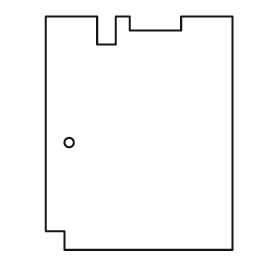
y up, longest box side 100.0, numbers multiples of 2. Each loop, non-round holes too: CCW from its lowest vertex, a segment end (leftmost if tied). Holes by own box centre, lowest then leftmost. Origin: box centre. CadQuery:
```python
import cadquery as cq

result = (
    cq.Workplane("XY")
    .moveTo(-32.0, -50.0)
    .lineTo(40.0, -50.0)
    .lineTo(40.0, 50.0)
    .lineTo(18.0, 50.0)
    .lineTo(18.0, 44.0)
    .lineTo(-4.0, 44.0)
    .lineTo(-4.0, 50.0)
    .lineTo(-10.0, 50.0)
    .lineTo(-10.0, 38.0)
    .lineTo(-18.0, 38.0)
    .lineTo(-18.0, 50.0)
    .lineTo(-40.0, 50.0)
    .lineTo(-40.0, -42.0)
    .lineTo(-32.0, -42.0)
    .close()
    .moveTo(-30.0, -4.0)
    .circle(2.0)
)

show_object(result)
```